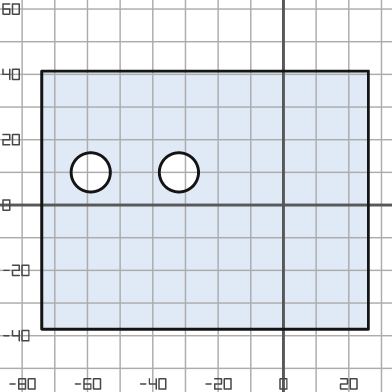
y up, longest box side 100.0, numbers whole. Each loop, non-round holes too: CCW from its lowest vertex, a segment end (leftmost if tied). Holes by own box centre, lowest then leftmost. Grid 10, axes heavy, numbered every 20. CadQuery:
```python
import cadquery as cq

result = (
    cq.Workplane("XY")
    .moveTo(-74.0, -38.0)
    .lineTo(26.0, -38.0)
    .lineTo(26.0, 41.0)
    .lineTo(-74.0, 41.0)
    .close()
    .moveTo(-59.0, 10.0)
    .circle(6.0)
    .moveTo(-32.0, 10.0)
    .circle(6.0)
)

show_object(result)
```